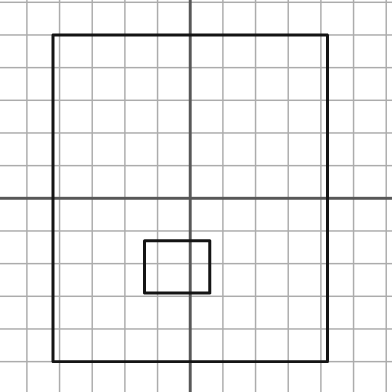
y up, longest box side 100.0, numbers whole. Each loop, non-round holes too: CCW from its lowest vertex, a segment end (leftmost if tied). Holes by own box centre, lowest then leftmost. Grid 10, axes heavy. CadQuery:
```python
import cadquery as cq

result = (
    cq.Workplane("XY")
    .moveTo(-42.0, -50.0)
    .lineTo(42.0, -50.0)
    .lineTo(42.0, 50.0)
    .lineTo(-42.0, 50.0)
    .close()
    .moveTo(-14.0, -29.0)
    .lineTo(6.0, -29.0)
    .lineTo(6.0, -13.0)
    .lineTo(-14.0, -13.0)
    .close()
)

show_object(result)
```